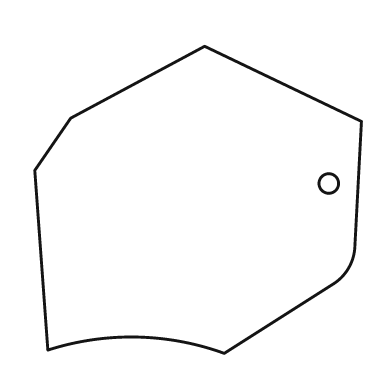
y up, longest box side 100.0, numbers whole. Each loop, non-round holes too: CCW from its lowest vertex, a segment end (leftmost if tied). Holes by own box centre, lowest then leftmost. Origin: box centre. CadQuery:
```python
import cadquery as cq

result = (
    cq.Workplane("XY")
    .moveTo(8.0, -47.0)
    .lineTo(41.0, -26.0)
    .threePointArc((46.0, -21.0), (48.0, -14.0))
    .lineTo(50.0, 24.0)
    .lineTo(2.0, 47.0)
    .lineTo(-39.0, 25.0)
    .lineTo(-50.0, 9.0)
    .lineTo(-46.0, -46.0)
    .threePointArc((-19.0, -42.0), (8.0, -47.0))
    .close()
    .moveTo(40.0, 5.0)
    .circle(3.0)
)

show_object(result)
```